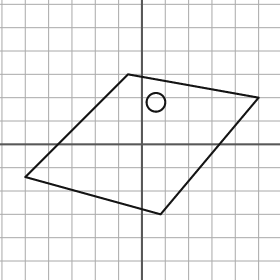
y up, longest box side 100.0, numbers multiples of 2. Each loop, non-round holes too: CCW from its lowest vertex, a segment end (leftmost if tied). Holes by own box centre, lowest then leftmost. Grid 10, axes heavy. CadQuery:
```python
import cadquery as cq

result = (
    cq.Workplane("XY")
    .moveTo(8.0, -30.0)
    .lineTo(50.0, 20.0)
    .lineTo(-6.0, 30.0)
    .lineTo(-50.0, -14.0)
    .close()
    .moveTo(6.0, 18.0)
    .circle(4.0)
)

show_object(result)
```